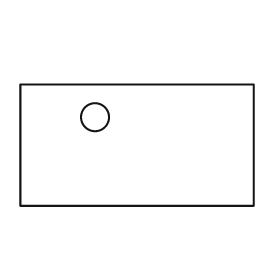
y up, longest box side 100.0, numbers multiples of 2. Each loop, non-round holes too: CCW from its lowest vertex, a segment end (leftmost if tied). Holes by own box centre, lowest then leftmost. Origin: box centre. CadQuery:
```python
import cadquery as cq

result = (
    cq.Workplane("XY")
    .moveTo(-50.0, -26.0)
    .lineTo(50.0, -26.0)
    .lineTo(50.0, 26.0)
    .lineTo(-50.0, 26.0)
    .close()
    .moveTo(-18.0, 12.0)
    .circle(6.0)
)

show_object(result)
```